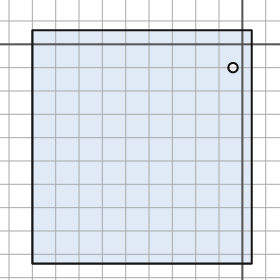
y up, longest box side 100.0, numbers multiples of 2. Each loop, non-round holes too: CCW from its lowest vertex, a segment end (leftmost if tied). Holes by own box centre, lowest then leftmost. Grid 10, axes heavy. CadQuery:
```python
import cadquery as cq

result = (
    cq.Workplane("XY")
    .moveTo(-90.0, -94.0)
    .lineTo(4.0, -94.0)
    .lineTo(4.0, 6.0)
    .lineTo(-90.0, 6.0)
    .close()
    .moveTo(-4.0, -10.0)
    .circle(2.0)
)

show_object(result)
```